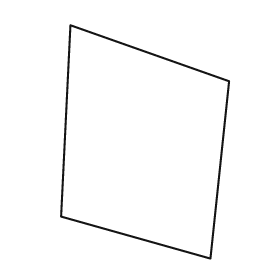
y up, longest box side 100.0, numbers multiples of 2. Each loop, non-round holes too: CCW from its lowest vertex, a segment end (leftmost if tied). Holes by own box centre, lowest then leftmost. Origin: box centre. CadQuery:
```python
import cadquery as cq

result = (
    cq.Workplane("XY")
    .moveTo(28.0, -50.0)
    .lineTo(36.0, 26.0)
    .lineTo(-32.0, 50.0)
    .lineTo(-36.0, -32.0)
    .close()
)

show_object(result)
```